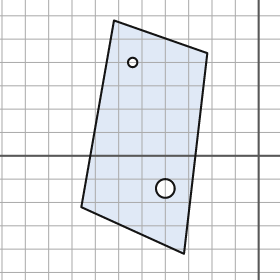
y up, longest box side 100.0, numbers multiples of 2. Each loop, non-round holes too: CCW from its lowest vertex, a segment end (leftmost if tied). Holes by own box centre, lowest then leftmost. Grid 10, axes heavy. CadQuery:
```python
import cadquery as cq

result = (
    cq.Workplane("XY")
    .moveTo(-32.0, -42.0)
    .lineTo(-22.0, 44.0)
    .lineTo(-62.0, 58.0)
    .lineTo(-76.0, -22.0)
    .close()
    .moveTo(-40.0, -14.0)
    .circle(4.0)
    .moveTo(-54.0, 40.0)
    .circle(2.0)
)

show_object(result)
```